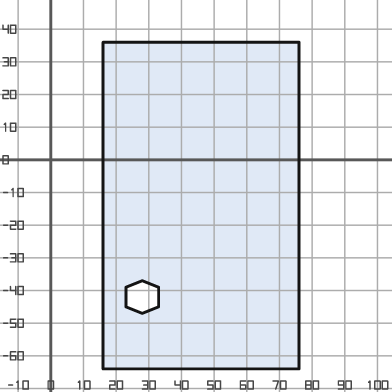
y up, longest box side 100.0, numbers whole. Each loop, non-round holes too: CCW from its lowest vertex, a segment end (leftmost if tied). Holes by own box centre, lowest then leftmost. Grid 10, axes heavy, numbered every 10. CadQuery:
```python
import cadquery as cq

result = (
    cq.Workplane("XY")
    .moveTo(16.0, -64.0)
    .lineTo(76.0, -64.0)
    .lineTo(76.0, 36.0)
    .lineTo(16.0, 36.0)
    .close()
    .moveTo(28.0, -47.0)
    .lineTo(33.0, -45.0)
    .lineTo(33.0, -39.0)
    .lineTo(28.0, -37.0)
    .lineTo(23.0, -39.0)
    .lineTo(23.0, -45.0)
    .close()
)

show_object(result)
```